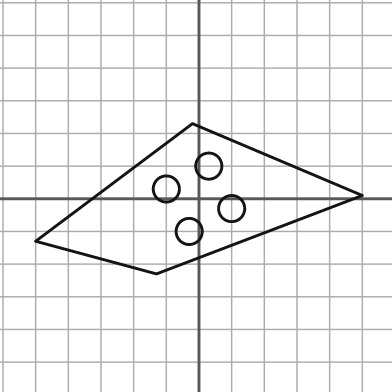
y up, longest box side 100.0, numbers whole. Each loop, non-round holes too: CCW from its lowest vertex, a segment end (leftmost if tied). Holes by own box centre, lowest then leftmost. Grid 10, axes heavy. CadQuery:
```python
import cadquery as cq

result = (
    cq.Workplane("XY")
    .moveTo(-13.0, -23.0)
    .lineTo(50.0, 1.0)
    .lineTo(-2.0, 23.0)
    .lineTo(-50.0, -13.0)
    .close()
    .moveTo(-3.0, -10.0)
    .circle(4.0)
    .moveTo(10.0, -3.0)
    .circle(4.0)
    .moveTo(-10.0, 3.0)
    .circle(4.0)
    .moveTo(3.0, 10.0)
    .circle(4.0)
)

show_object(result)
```